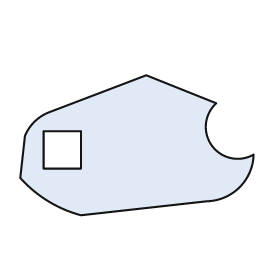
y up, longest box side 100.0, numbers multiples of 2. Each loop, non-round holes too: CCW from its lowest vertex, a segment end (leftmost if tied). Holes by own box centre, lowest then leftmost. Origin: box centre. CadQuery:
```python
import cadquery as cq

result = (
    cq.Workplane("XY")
    .moveTo(-24.0, -30.0)
    .lineTo(30.0, -24.0)
    .threePointArc((44.0, -18.0), (50.0, -4.0))
    .threePointArc((32.0, 0.0), (34.0, 18.0))
    .lineTo(4.0, 30.0)
    .lineTo(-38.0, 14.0)
    .threePointArc((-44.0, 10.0), (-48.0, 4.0))
    .lineTo(-50.0, -14.0)
    .threePointArc((-38.0, -24.0), (-24.0, -30.0))
    .close()
    .moveTo(-40.0, -10.0)
    .lineTo(-24.0, -10.0)
    .lineTo(-24.0, 6.0)
    .lineTo(-40.0, 6.0)
    .close()
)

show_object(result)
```